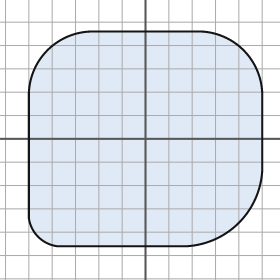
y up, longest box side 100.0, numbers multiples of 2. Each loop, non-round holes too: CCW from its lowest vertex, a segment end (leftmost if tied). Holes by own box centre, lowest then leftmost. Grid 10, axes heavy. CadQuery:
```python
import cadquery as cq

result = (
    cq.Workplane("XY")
    .moveTo(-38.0, -46.0)
    .lineTo(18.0, -46.0)
    .threePointArc((40.0, -36.0), (50.0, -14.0))
    .lineTo(50.0, 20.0)
    .threePointArc((42.0, 38.0), (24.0, 46.0))
    .lineTo(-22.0, 46.0)
    .threePointArc((-42.0, 38.0), (-50.0, 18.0))
    .lineTo(-50.0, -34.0)
    .threePointArc((-46.0, -42.0), (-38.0, -46.0))
    .close()
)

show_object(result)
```